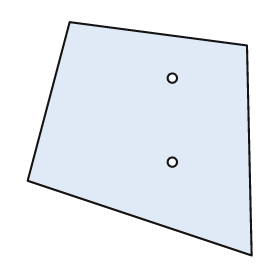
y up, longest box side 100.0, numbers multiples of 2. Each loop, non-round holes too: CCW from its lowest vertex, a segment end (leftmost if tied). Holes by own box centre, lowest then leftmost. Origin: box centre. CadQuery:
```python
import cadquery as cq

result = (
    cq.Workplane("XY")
    .moveTo(48.0, -50.0)
    .lineTo(46.0, 40.0)
    .lineTo(-30.0, 50.0)
    .lineTo(-48.0, -18.0)
    .close()
    .moveTo(14.0, -10.0)
    .circle(2.0)
    .moveTo(14.0, 26.0)
    .circle(2.0)
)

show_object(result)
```